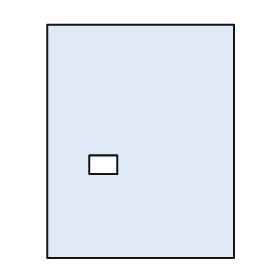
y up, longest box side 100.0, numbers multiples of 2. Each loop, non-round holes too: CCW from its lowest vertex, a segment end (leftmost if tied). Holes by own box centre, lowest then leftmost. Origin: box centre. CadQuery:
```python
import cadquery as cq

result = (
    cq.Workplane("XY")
    .moveTo(-40.0, -50.0)
    .lineTo(40.0, -50.0)
    .lineTo(40.0, 50.0)
    .lineTo(-40.0, 50.0)
    .close()
    .moveTo(-22.0, -14.0)
    .lineTo(-10.0, -14.0)
    .lineTo(-10.0, -6.0)
    .lineTo(-22.0, -6.0)
    .close()
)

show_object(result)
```